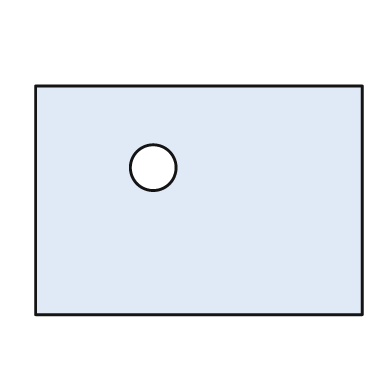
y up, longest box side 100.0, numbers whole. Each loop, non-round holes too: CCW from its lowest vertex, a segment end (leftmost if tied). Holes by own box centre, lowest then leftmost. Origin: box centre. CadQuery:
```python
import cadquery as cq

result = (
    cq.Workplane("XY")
    .moveTo(-50.0, -35.0)
    .lineTo(50.0, -35.0)
    .lineTo(50.0, 35.0)
    .lineTo(-50.0, 35.0)
    .close()
    .moveTo(-14.0, 10.0)
    .circle(7.0)
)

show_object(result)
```